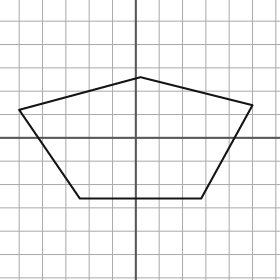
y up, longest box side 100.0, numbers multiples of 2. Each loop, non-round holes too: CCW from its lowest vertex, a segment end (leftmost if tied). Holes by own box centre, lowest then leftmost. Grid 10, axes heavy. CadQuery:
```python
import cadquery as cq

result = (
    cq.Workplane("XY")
    .moveTo(-24.0, -26.0)
    .lineTo(28.0, -26.0)
    .lineTo(50.0, 14.0)
    .lineTo(2.0, 26.0)
    .lineTo(-50.0, 12.0)
    .close()
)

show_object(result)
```